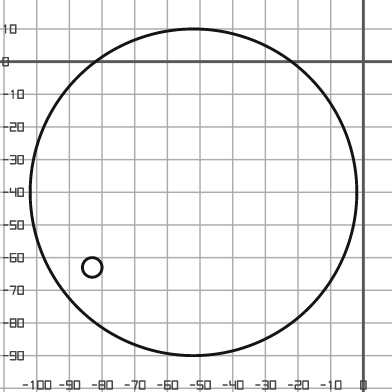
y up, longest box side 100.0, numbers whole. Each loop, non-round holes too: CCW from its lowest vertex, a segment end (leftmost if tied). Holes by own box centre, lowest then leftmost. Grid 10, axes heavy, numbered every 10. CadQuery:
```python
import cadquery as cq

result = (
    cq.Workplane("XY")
    .moveTo(-52.0, -40.0)
    .circle(50.0)
    .moveTo(-83.0, -63.0)
    .circle(3.0)
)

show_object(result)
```